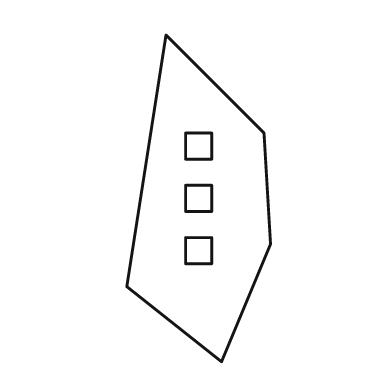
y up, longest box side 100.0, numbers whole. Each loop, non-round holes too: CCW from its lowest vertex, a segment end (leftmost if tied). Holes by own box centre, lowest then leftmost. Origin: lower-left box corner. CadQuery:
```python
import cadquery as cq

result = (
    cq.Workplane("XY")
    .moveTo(29.0, 0.0)
    .lineTo(44.0, 36.0)
    .lineTo(42.0, 70.0)
    .lineTo(12.0, 100.0)
    .lineTo(0.0, 23.0)
    .close()
    .moveTo(18.0, 30.0)
    .lineTo(26.0, 30.0)
    .lineTo(26.0, 38.0)
    .lineTo(18.0, 38.0)
    .close()
    .moveTo(18.0, 46.0)
    .lineTo(26.0, 46.0)
    .lineTo(26.0, 54.0)
    .lineTo(18.0, 54.0)
    .close()
    .moveTo(18.0, 62.0)
    .lineTo(26.0, 62.0)
    .lineTo(26.0, 70.0)
    .lineTo(18.0, 70.0)
    .close()
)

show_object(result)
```